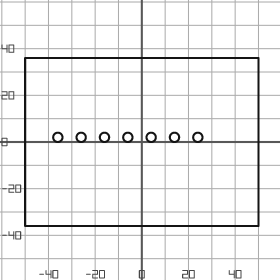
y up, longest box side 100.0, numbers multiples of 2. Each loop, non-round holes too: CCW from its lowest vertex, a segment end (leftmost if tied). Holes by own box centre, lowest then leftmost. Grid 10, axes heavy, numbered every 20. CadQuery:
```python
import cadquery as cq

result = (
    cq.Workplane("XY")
    .moveTo(-50.0, -36.0)
    .lineTo(50.0, -36.0)
    .lineTo(50.0, 36.0)
    .lineTo(-50.0, 36.0)
    .close()
    .moveTo(-36.0, 2.0)
    .circle(2.0)
    .moveTo(-26.0, 2.0)
    .circle(2.0)
    .moveTo(-16.0, 2.0)
    .circle(2.0)
    .moveTo(-6.0, 2.0)
    .circle(2.0)
    .moveTo(4.0, 2.0)
    .circle(2.0)
    .moveTo(14.0, 2.0)
    .circle(2.0)
    .moveTo(24.0, 2.0)
    .circle(2.0)
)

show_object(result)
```